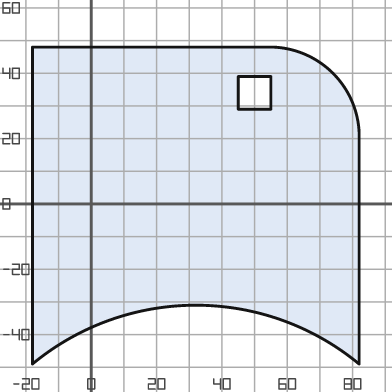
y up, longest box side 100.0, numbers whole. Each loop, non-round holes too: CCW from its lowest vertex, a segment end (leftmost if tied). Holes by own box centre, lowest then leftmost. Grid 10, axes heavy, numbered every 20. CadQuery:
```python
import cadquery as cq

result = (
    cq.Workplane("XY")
    .moveTo(-18.0, -49.0)
    .threePointArc((32.0, -31.0), (82.0, -49.0))
    .lineTo(82.0, 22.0)
    .threePointArc((74.0, 40.0), (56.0, 48.0))
    .lineTo(-18.0, 48.0)
    .close()
    .moveTo(45.0, 29.0)
    .lineTo(55.0, 29.0)
    .lineTo(55.0, 39.0)
    .lineTo(45.0, 39.0)
    .close()
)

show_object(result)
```